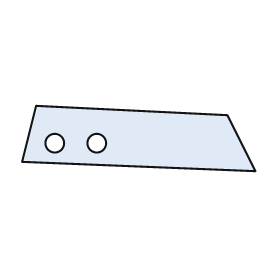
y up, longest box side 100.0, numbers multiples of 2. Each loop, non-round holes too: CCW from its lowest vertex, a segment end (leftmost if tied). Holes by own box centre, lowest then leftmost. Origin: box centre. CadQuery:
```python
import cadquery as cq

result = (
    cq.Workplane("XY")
    .moveTo(50.0, -14.0)
    .lineTo(38.0, 10.0)
    .lineTo(-44.0, 14.0)
    .lineTo(-50.0, -10.0)
    .close()
    .moveTo(-36.0, -2.0)
    .circle(4.0)
    .moveTo(-18.0, -2.0)
    .circle(4.0)
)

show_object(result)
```